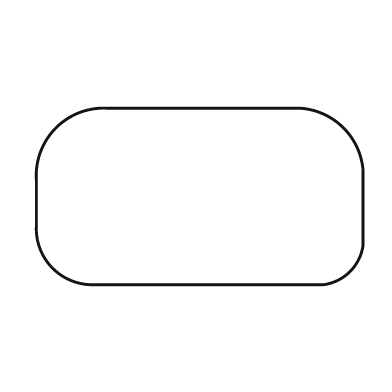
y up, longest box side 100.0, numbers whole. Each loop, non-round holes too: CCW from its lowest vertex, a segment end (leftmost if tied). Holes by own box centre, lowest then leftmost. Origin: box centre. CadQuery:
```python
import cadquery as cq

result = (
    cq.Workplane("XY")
    .moveTo(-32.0, -27.0)
    .lineTo(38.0, -27.0)
    .threePointArc((46.0, -23.0), (50.0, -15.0))
    .lineTo(50.0, 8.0)
    .threePointArc((44.0, 21.0), (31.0, 27.0))
    .lineTo(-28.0, 27.0)
    .threePointArc((-44.0, 21.0), (-50.0, 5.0))
    .lineTo(-50.0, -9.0)
    .threePointArc((-45.0, -22.0), (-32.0, -27.0))
    .close()
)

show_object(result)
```